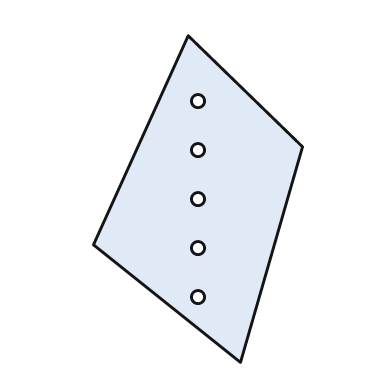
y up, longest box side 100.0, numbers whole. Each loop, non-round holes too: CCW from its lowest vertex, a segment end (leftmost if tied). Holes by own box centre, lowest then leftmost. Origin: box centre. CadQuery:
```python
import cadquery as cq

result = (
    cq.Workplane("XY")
    .moveTo(13.0, -50.0)
    .lineTo(32.0, 16.0)
    .lineTo(-3.0, 50.0)
    .lineTo(-32.0, -14.0)
    .close()
    .moveTo(0.0, -30.0)
    .circle(2.0)
    .moveTo(0.0, -15.0)
    .circle(2.0)
    .moveTo(0.0, 0.0)
    .circle(2.0)
    .moveTo(0.0, 15.0)
    .circle(2.0)
    .moveTo(0.0, 30.0)
    .circle(2.0)
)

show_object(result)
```